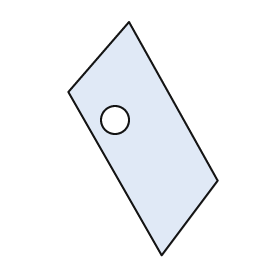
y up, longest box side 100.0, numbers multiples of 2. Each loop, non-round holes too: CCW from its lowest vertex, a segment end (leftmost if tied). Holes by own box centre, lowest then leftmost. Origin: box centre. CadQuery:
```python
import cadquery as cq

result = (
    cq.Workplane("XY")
    .moveTo(8.0, -50.0)
    .lineTo(32.0, -18.0)
    .lineTo(-6.0, 50.0)
    .lineTo(-32.0, 20.0)
    .close()
    .moveTo(-12.0, 8.0)
    .circle(6.0)
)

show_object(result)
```